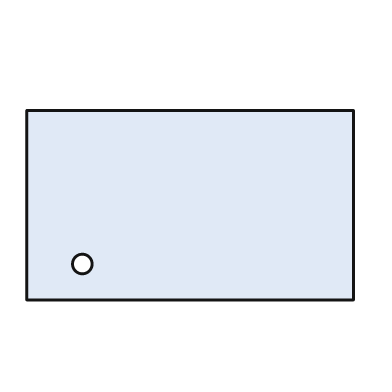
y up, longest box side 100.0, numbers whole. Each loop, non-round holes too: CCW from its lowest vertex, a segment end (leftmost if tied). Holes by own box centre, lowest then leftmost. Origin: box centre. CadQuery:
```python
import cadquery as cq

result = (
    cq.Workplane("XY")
    .moveTo(-50.0, -29.0)
    .lineTo(50.0, -29.0)
    .lineTo(50.0, 29.0)
    .lineTo(-50.0, 29.0)
    .close()
    .moveTo(-33.0, -18.0)
    .circle(3.0)
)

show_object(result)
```